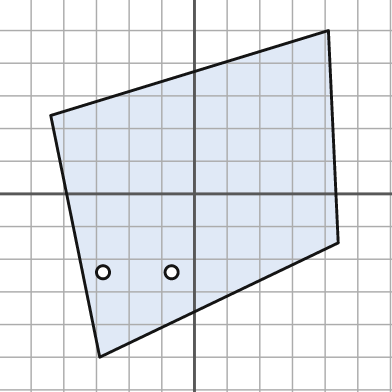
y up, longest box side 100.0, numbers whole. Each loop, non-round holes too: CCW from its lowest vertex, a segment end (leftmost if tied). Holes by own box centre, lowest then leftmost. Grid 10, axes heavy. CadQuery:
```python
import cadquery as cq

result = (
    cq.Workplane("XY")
    .moveTo(-29.0, -50.0)
    .lineTo(44.0, -15.0)
    .lineTo(41.0, 50.0)
    .lineTo(-44.0, 24.0)
    .close()
    .moveTo(-28.0, -24.0)
    .circle(2.0)
    .moveTo(-7.0, -24.0)
    .circle(2.0)
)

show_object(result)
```